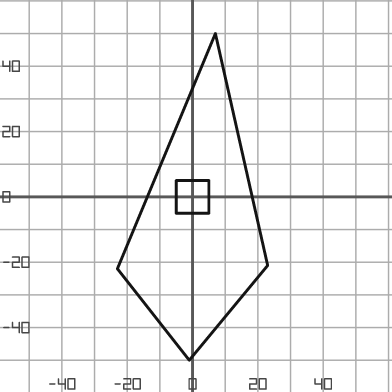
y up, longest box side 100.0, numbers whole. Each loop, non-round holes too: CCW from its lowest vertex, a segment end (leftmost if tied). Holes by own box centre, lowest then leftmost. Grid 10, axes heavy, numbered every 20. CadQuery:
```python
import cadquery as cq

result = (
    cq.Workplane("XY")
    .moveTo(-1.0, -50.0)
    .lineTo(23.0, -21.0)
    .lineTo(7.0, 50.0)
    .lineTo(-23.0, -22.0)
    .close()
    .moveTo(-5.0, -5.0)
    .lineTo(5.0, -5.0)
    .lineTo(5.0, 5.0)
    .lineTo(-5.0, 5.0)
    .close()
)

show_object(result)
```